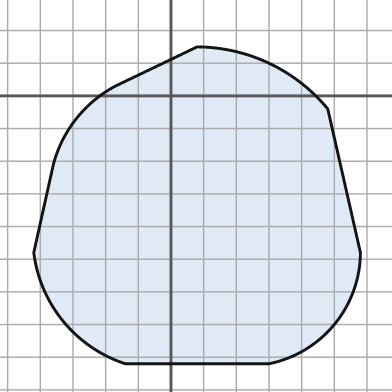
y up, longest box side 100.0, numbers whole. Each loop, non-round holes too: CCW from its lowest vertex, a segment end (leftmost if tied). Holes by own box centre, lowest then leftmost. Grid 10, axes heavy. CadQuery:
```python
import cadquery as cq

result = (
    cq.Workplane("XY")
    .moveTo(-14.0, -82.0)
    .lineTo(30.0, -82.0)
    .threePointArc((50.0, -70.0), (58.0, -48.0))
    .lineTo(48.0, -4.0)
    .threePointArc((30.0, 10.0), (8.0, 15.0))
    .lineTo(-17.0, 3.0)
    .threePointArc((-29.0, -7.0), (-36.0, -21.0))
    .lineTo(-42.0, -48.0)
    .threePointArc((-33.0, -69.0), (-14.0, -82.0))
    .close()
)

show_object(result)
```